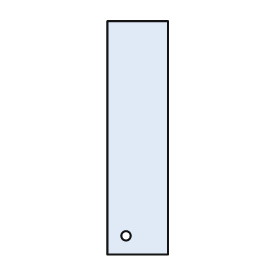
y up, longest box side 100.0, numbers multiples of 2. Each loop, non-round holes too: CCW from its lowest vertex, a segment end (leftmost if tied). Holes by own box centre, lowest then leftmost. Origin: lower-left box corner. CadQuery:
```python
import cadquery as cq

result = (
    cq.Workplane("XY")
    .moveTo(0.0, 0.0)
    .lineTo(26.0, 0.0)
    .lineTo(26.0, 100.0)
    .lineTo(0.0, 100.0)
    .close()
    .moveTo(8.0, 8.0)
    .circle(2.0)
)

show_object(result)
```